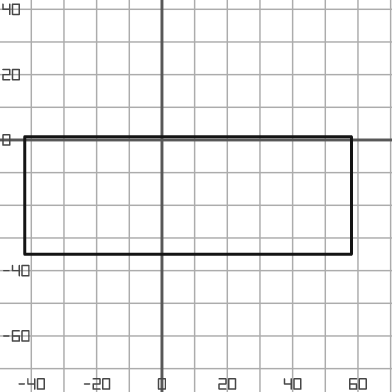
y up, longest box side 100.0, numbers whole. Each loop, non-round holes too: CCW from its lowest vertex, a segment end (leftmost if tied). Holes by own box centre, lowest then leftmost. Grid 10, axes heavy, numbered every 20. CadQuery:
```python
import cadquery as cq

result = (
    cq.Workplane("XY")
    .moveTo(-42.0, -35.0)
    .lineTo(58.0, -35.0)
    .lineTo(58.0, 1.0)
    .lineTo(-42.0, 1.0)
    .close()
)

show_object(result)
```